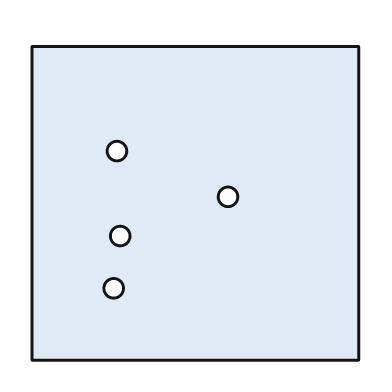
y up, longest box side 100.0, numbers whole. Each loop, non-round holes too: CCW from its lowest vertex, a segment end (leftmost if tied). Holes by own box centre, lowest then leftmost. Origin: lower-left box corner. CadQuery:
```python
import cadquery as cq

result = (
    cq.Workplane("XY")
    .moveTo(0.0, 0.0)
    .lineTo(100.0, 0.0)
    .lineTo(100.0, 96.0)
    .lineTo(0.0, 96.0)
    .close()
    .moveTo(25.0, 22.0)
    .circle(3.0)
    .moveTo(27.0, 38.0)
    .circle(3.0)
    .moveTo(60.0, 50.0)
    .circle(3.0)
    .moveTo(26.0, 64.0)
    .circle(3.0)
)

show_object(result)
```